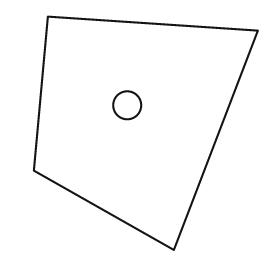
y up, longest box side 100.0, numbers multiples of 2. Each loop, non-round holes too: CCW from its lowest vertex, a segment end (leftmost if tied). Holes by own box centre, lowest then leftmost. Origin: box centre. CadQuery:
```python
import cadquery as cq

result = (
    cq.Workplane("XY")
    .moveTo(12.0, -50.0)
    .lineTo(48.0, 44.0)
    .lineTo(-42.0, 50.0)
    .lineTo(-48.0, -16.0)
    .close()
    .moveTo(-8.0, 12.0)
    .circle(6.0)
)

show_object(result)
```